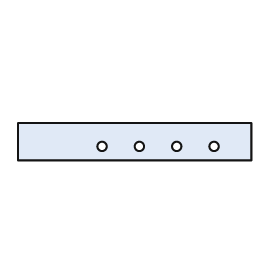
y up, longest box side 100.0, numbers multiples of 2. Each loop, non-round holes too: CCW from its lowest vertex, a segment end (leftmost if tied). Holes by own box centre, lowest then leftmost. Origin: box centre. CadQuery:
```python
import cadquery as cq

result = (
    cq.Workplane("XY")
    .moveTo(-50.0, -8.0)
    .lineTo(50.0, -8.0)
    .lineTo(50.0, 8.0)
    .lineTo(-50.0, 8.0)
    .close()
    .moveTo(-14.0, -2.0)
    .circle(2.0)
    .moveTo(2.0, -2.0)
    .circle(2.0)
    .moveTo(18.0, -2.0)
    .circle(2.0)
    .moveTo(34.0, -2.0)
    .circle(2.0)
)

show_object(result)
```